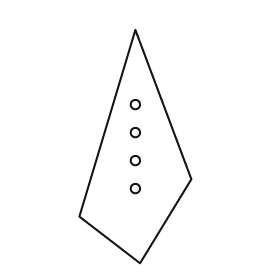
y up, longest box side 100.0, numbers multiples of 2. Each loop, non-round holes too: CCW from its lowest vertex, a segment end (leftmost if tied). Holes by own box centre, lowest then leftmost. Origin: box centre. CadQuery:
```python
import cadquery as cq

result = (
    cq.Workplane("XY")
    .moveTo(2.0, -50.0)
    .lineTo(24.0, -14.0)
    .lineTo(0.0, 50.0)
    .lineTo(-24.0, -30.0)
    .close()
    .moveTo(0.0, -18.0)
    .circle(2.0)
    .moveTo(0.0, -6.0)
    .circle(2.0)
    .moveTo(0.0, 6.0)
    .circle(2.0)
    .moveTo(0.0, 18.0)
    .circle(2.0)
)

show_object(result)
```